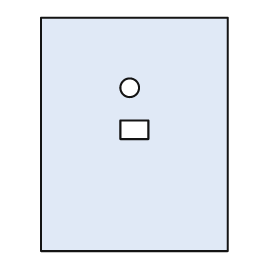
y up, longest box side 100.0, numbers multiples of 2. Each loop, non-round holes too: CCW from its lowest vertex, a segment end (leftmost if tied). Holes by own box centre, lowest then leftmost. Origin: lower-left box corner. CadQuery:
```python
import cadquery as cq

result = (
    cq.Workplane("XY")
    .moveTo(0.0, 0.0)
    .lineTo(80.0, 0.0)
    .lineTo(80.0, 100.0)
    .lineTo(0.0, 100.0)
    .close()
    .moveTo(34.0, 48.0)
    .lineTo(46.0, 48.0)
    .lineTo(46.0, 56.0)
    .lineTo(34.0, 56.0)
    .close()
    .moveTo(38.0, 70.0)
    .circle(4.0)
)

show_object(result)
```